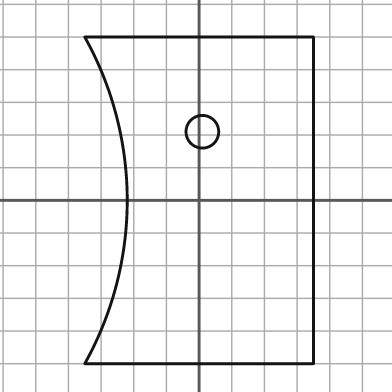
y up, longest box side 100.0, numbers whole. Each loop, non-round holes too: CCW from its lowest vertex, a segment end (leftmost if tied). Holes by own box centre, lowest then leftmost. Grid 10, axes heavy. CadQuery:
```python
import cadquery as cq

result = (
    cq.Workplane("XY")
    .moveTo(-35.0, -50.0)
    .lineTo(35.0, -50.0)
    .lineTo(35.0, 50.0)
    .lineTo(-35.0, 50.0)
    .threePointArc((-22.0, 0.0), (-35.0, -50.0))
    .close()
    .moveTo(1.0, 21.0)
    .circle(5.0)
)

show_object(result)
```